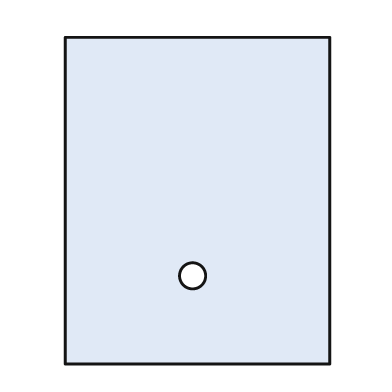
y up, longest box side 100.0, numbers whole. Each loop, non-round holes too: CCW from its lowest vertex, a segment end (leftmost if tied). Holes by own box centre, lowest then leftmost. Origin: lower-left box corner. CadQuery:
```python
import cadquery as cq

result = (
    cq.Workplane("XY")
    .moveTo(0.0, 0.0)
    .lineTo(81.0, 0.0)
    .lineTo(81.0, 100.0)
    .lineTo(0.0, 100.0)
    .close()
    .moveTo(39.0, 27.0)
    .circle(4.0)
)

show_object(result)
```